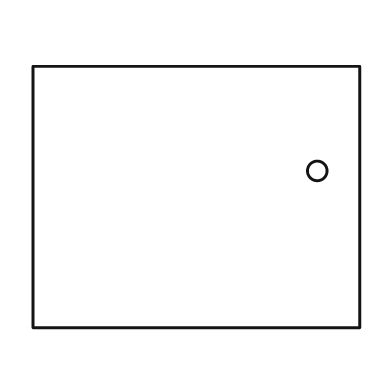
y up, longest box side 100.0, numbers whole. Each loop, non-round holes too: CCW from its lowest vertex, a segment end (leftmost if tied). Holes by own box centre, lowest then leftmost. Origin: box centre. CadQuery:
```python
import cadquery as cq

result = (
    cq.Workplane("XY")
    .moveTo(-50.0, -40.0)
    .lineTo(50.0, -40.0)
    .lineTo(50.0, 40.0)
    .lineTo(-50.0, 40.0)
    .close()
    .moveTo(37.0, 8.0)
    .circle(3.0)
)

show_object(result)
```